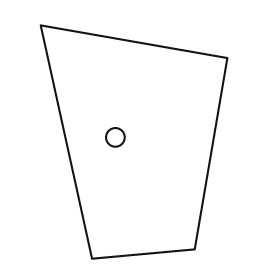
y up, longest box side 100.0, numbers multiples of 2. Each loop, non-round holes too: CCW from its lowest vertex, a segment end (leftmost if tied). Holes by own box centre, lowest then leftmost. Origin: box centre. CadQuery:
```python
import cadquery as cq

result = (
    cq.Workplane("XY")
    .moveTo(-18.0, -50.0)
    .lineTo(26.0, -46.0)
    .lineTo(40.0, 36.0)
    .lineTo(-40.0, 50.0)
    .close()
    .moveTo(-8.0, 2.0)
    .circle(4.0)
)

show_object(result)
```